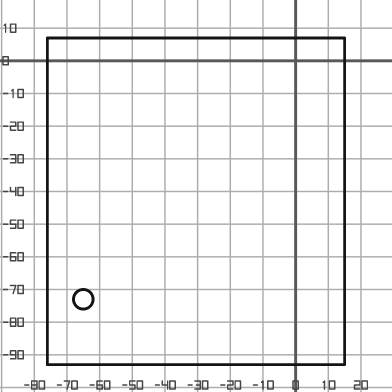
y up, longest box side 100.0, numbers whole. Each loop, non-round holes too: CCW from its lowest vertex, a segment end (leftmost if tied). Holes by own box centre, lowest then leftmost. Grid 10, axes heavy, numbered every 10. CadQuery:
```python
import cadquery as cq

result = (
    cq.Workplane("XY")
    .moveTo(-76.0, -93.0)
    .lineTo(15.0, -93.0)
    .lineTo(15.0, 7.0)
    .lineTo(-76.0, 7.0)
    .close()
    .moveTo(-65.0, -73.0)
    .circle(3.0)
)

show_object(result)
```